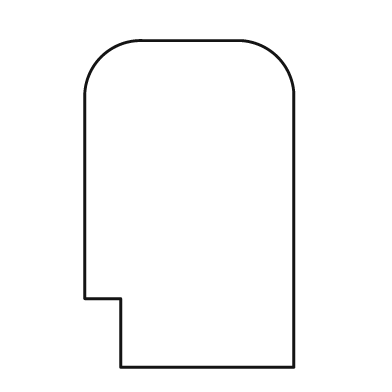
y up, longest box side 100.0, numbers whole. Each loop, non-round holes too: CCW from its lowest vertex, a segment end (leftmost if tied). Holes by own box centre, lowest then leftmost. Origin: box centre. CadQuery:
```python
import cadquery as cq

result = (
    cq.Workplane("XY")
    .moveTo(-21.0, -50.0)
    .lineTo(32.0, -50.0)
    .lineTo(32.0, 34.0)
    .threePointArc((27.0, 45.0), (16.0, 50.0))
    .lineTo(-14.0, 50.0)
    .threePointArc((-27.0, 45.0), (-32.0, 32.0))
    .lineTo(-32.0, -29.0)
    .lineTo(-21.0, -29.0)
    .close()
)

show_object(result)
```